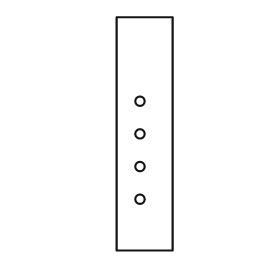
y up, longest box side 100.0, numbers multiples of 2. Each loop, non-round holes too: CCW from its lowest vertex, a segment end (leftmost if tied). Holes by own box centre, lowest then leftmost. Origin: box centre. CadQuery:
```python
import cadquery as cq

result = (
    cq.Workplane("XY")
    .moveTo(-12.0, -50.0)
    .lineTo(12.0, -50.0)
    .lineTo(12.0, 50.0)
    .lineTo(-12.0, 50.0)
    .close()
    .moveTo(-2.0, -28.0)
    .circle(2.0)
    .moveTo(-2.0, -14.0)
    .circle(2.0)
    .moveTo(-2.0, 0.0)
    .circle(2.0)
    .moveTo(-2.0, 14.0)
    .circle(2.0)
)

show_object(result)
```